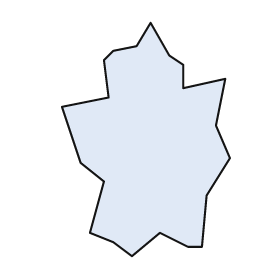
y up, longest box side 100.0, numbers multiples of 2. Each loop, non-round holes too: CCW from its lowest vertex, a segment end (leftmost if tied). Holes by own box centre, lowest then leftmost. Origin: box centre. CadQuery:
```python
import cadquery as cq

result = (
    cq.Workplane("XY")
    .moveTo(-6.0, -50.0)
    .lineTo(6.0, -40.0)
    .lineTo(18.0, -46.0)
    .lineTo(24.0, -46.0)
    .lineTo(26.0, -24.0)
    .lineTo(36.0, -8.0)
    .lineTo(30.0, 6.0)
    .lineTo(34.0, 26.0)
    .lineTo(16.0, 22.0)
    .lineTo(16.0, 32.0)
    .lineTo(10.0, 36.0)
    .lineTo(2.0, 50.0)
    .lineTo(-4.0, 40.0)
    .lineTo(-14.0, 38.0)
    .lineTo(-18.0, 34.0)
    .lineTo(-16.0, 18.0)
    .lineTo(-36.0, 14.0)
    .lineTo(-28.0, -10.0)
    .lineTo(-18.0, -18.0)
    .lineTo(-24.0, -40.0)
    .lineTo(-14.0, -44.0)
    .close()
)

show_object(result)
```